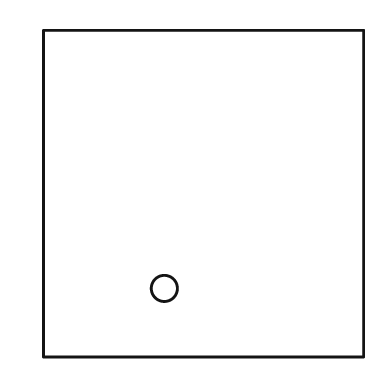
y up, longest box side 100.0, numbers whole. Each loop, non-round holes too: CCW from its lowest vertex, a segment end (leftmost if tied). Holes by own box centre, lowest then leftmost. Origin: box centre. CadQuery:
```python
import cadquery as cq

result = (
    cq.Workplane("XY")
    .moveTo(-49.0, -50.0)
    .lineTo(49.0, -50.0)
    .lineTo(49.0, 50.0)
    .lineTo(-49.0, 50.0)
    .close()
    .moveTo(-12.0, -29.0)
    .circle(4.0)
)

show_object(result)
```